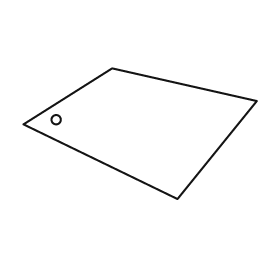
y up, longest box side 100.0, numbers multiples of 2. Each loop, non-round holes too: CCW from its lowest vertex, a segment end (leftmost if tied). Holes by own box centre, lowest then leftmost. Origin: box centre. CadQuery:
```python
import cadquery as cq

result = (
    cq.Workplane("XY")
    .moveTo(16.0, -28.0)
    .lineTo(50.0, 14.0)
    .lineTo(-12.0, 28.0)
    .lineTo(-50.0, 4.0)
    .close()
    .moveTo(-36.0, 6.0)
    .circle(2.0)
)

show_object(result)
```